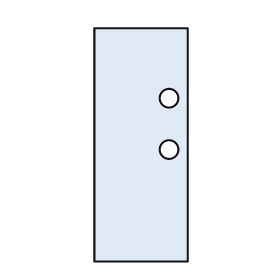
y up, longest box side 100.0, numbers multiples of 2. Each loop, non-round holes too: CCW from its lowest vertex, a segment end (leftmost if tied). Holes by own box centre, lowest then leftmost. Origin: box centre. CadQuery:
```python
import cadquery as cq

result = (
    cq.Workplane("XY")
    .moveTo(-20.0, -50.0)
    .lineTo(20.0, -50.0)
    .lineTo(20.0, 50.0)
    .lineTo(-20.0, 50.0)
    .close()
    .moveTo(12.0, -2.0)
    .circle(4.0)
    .moveTo(12.0, 20.0)
    .circle(4.0)
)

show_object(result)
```